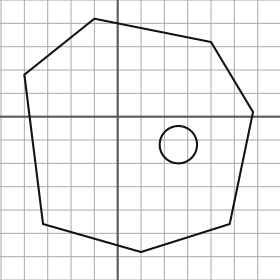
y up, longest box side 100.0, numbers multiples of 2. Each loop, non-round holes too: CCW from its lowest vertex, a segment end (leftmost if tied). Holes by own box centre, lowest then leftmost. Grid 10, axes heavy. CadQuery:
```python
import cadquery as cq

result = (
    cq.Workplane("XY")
    .moveTo(10.0, -58.0)
    .lineTo(48.0, -46.0)
    .lineTo(58.0, 2.0)
    .lineTo(40.0, 32.0)
    .lineTo(-10.0, 42.0)
    .lineTo(-40.0, 18.0)
    .lineTo(-32.0, -46.0)
    .close()
    .moveTo(26.0, -12.0)
    .circle(8.0)
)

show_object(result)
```